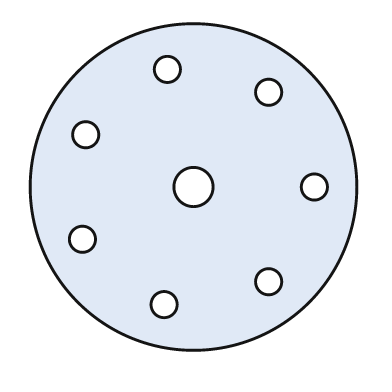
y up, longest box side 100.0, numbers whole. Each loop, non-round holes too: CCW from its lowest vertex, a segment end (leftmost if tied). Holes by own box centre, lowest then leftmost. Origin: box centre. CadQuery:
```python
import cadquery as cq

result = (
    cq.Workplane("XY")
    .moveTo(0.0, 0.0)
    .circle(50.0)
    .moveTo(-9.0, -36.0)
    .circle(4.0)
    .moveTo(23.0, -29.0)
    .circle(4.0)
    .moveTo(-34.0, -16.0)
    .circle(4.0)
    .moveTo(0.0, 0.0)
    .circle(6.0)
    .moveTo(37.0, 0.0)
    .circle(4.0)
    .moveTo(-33.0, 16.0)
    .circle(4.0)
    .moveTo(23.0, 29.0)
    .circle(4.0)
    .moveTo(-8.0, 36.0)
    .circle(4.0)
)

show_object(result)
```